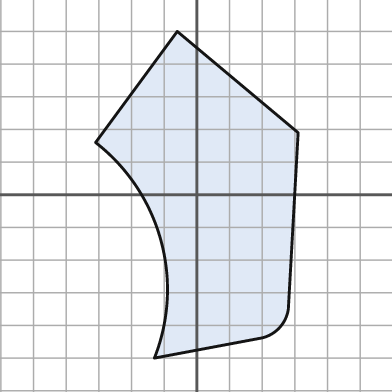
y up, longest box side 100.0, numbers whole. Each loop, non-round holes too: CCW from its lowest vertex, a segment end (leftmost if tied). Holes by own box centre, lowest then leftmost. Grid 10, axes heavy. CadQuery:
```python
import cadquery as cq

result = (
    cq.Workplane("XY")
    .moveTo(-13.0, -50.0)
    .lineTo(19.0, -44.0)
    .threePointArc((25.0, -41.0), (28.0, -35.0))
    .lineTo(31.0, 19.0)
    .lineTo(-6.0, 50.0)
    .lineTo(-31.0, 16.0)
    .threePointArc((-11.0, -14.0), (-13.0, -50.0))
    .close()
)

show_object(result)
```